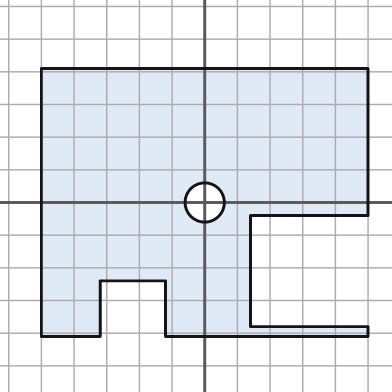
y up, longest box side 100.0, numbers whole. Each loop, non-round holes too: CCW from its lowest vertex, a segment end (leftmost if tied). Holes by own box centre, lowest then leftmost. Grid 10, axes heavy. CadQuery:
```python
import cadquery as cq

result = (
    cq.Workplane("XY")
    .moveTo(-50.0, -41.0)
    .lineTo(-32.0, -41.0)
    .lineTo(-32.0, -24.0)
    .lineTo(-12.0, -24.0)
    .lineTo(-12.0, -41.0)
    .lineTo(50.0, -41.0)
    .lineTo(50.0, -38.0)
    .lineTo(14.0, -38.0)
    .lineTo(14.0, -4.0)
    .lineTo(50.0, -4.0)
    .lineTo(50.0, 41.0)
    .lineTo(-50.0, 41.0)
    .close()
    .moveTo(0.0, 0.0)
    .circle(6.0)
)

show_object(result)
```